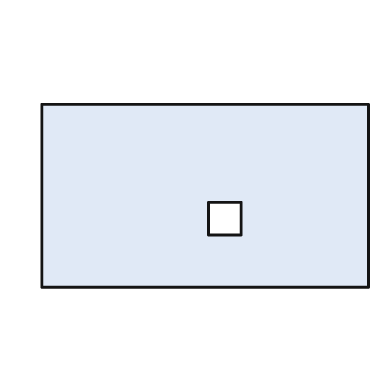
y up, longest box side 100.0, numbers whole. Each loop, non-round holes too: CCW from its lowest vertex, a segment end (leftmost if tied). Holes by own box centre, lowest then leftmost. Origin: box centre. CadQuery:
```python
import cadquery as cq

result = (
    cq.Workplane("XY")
    .moveTo(-50.0, -28.0)
    .lineTo(50.0, -28.0)
    .lineTo(50.0, 28.0)
    .lineTo(-50.0, 28.0)
    .close()
    .moveTo(1.0, -12.0)
    .lineTo(11.0, -12.0)
    .lineTo(11.0, -2.0)
    .lineTo(1.0, -2.0)
    .close()
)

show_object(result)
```